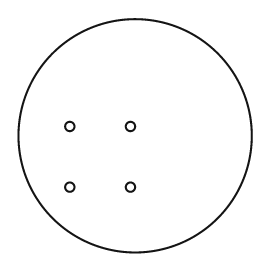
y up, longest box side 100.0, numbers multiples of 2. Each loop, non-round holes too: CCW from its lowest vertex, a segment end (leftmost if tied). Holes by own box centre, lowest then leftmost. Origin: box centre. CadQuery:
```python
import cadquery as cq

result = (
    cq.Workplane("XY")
    .moveTo(0.0, 0.0)
    .circle(50.0)
    .moveTo(-28.0, -22.0)
    .circle(2.0)
    .moveTo(-2.0, -22.0)
    .circle(2.0)
    .moveTo(-28.0, 4.0)
    .circle(2.0)
    .moveTo(-2.0, 4.0)
    .circle(2.0)
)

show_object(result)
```